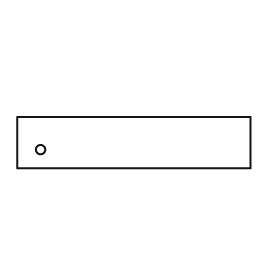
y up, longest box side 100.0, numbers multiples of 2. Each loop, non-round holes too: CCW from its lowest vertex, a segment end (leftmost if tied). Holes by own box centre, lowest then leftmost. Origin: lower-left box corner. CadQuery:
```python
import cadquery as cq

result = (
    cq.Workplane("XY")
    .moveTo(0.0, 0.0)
    .lineTo(100.0, 0.0)
    .lineTo(100.0, 22.0)
    .lineTo(0.0, 22.0)
    .close()
    .moveTo(10.0, 8.0)
    .circle(2.0)
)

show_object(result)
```